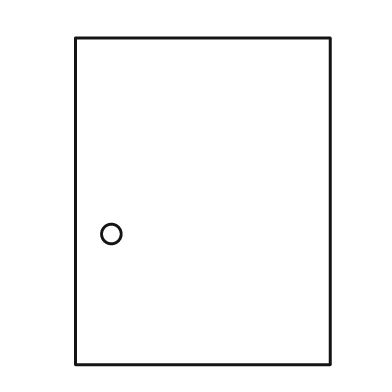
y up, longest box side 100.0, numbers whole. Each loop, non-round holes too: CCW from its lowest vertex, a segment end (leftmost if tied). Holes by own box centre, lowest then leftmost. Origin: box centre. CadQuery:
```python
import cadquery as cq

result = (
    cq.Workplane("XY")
    .moveTo(-39.0, -50.0)
    .lineTo(39.0, -50.0)
    .lineTo(39.0, 50.0)
    .lineTo(-39.0, 50.0)
    .close()
    .moveTo(-28.0, -10.0)
    .circle(3.0)
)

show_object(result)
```